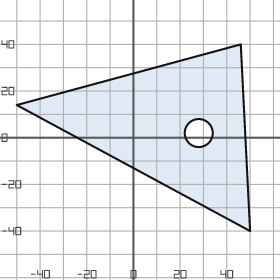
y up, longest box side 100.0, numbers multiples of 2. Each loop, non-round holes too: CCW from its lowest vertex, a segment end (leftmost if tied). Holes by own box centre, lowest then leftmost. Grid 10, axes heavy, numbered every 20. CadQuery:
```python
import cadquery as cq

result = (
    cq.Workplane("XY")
    .moveTo(50.0, -40.0)
    .lineTo(46.0, 40.0)
    .lineTo(-50.0, 14.0)
    .close()
    .moveTo(28.0, 2.0)
    .circle(6.0)
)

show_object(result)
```